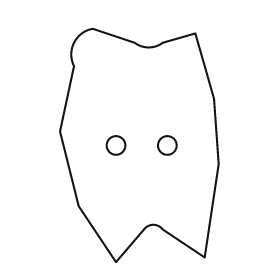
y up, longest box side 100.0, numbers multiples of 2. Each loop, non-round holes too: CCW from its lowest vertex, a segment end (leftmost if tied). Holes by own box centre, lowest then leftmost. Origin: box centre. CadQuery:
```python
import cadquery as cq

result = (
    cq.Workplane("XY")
    .moveTo(-10.0, -50.0)
    .lineTo(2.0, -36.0)
    .threePointArc((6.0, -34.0), (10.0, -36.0))
    .lineTo(28.0, -48.0)
    .lineTo(34.0, -8.0)
    .lineTo(32.0, 20.0)
    .lineTo(24.0, 48.0)
    .lineTo(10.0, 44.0)
    .threePointArc((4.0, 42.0), (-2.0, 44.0))
    .lineTo(-20.0, 50.0)
    .threePointArc((-28.0, 44.0), (-28.0, 34.0))
    .lineTo(-34.0, 6.0)
    .lineTo(-26.0, -26.0)
    .close()
    .moveTo(-10.0, 0.0)
    .circle(4.0)
    .moveTo(12.0, 0.0)
    .circle(4.0)
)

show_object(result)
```